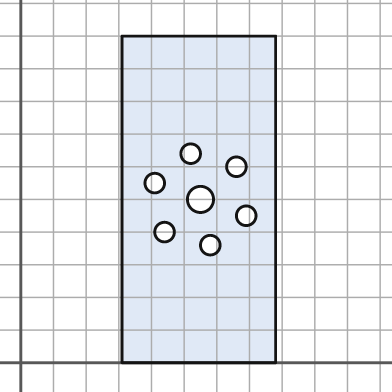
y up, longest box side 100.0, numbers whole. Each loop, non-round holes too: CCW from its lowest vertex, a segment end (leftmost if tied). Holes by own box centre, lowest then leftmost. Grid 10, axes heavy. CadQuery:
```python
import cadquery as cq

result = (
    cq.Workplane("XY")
    .moveTo(31.0, 0.0)
    .lineTo(78.0, 0.0)
    .lineTo(78.0, 100.0)
    .lineTo(31.0, 100.0)
    .close()
    .moveTo(58.0, 36.0)
    .circle(3.0)
    .moveTo(44.0, 40.0)
    .circle(3.0)
    .moveTo(69.0, 45.0)
    .circle(3.0)
    .moveTo(55.0, 50.0)
    .circle(4.0)
    .moveTo(41.0, 55.0)
    .circle(3.0)
    .moveTo(66.0, 60.0)
    .circle(3.0)
    .moveTo(52.0, 64.0)
    .circle(3.0)
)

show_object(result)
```